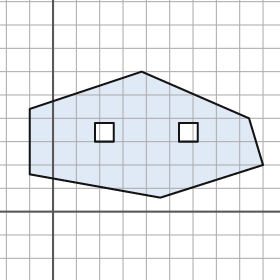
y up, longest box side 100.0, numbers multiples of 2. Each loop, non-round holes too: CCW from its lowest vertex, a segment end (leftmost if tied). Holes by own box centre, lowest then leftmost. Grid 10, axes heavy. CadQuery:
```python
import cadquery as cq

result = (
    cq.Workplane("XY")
    .moveTo(46.0, 6.0)
    .lineTo(90.0, 20.0)
    .lineTo(84.0, 40.0)
    .lineTo(38.0, 60.0)
    .lineTo(-10.0, 44.0)
    .lineTo(-10.0, 16.0)
    .close()
    .moveTo(18.0, 30.0)
    .lineTo(26.0, 30.0)
    .lineTo(26.0, 38.0)
    .lineTo(18.0, 38.0)
    .close()
    .moveTo(54.0, 30.0)
    .lineTo(62.0, 30.0)
    .lineTo(62.0, 38.0)
    .lineTo(54.0, 38.0)
    .close()
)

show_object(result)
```